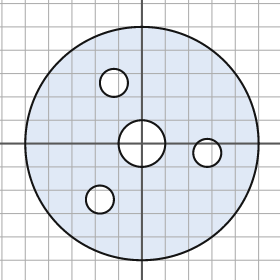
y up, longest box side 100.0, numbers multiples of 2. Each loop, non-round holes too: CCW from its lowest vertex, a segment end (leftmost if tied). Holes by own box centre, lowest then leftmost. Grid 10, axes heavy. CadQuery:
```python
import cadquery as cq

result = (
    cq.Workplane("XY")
    .moveTo(0.0, 0.0)
    .circle(50.0)
    .moveTo(-18.0, -24.0)
    .circle(6.0)
    .moveTo(28.0, -4.0)
    .circle(6.0)
    .moveTo(0.0, 0.0)
    .circle(10.0)
    .moveTo(-12.0, 26.0)
    .circle(6.0)
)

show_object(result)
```